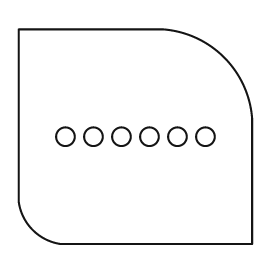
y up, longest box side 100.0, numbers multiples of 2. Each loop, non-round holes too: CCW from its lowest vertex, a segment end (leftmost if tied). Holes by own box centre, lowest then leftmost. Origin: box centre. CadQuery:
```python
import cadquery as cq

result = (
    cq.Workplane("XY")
    .moveTo(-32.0, -46.0)
    .lineTo(50.0, -46.0)
    .lineTo(50.0, 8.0)
    .threePointArc((38.0, 34.0), (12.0, 46.0))
    .lineTo(-50.0, 46.0)
    .lineTo(-50.0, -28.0)
    .threePointArc((-44.0, -40.0), (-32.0, -46.0))
    .close()
    .moveTo(-30.0, 0.0)
    .circle(4.0)
    .moveTo(-18.0, 0.0)
    .circle(4.0)
    .moveTo(-6.0, 0.0)
    .circle(4.0)
    .moveTo(6.0, 0.0)
    .circle(4.0)
    .moveTo(18.0, 0.0)
    .circle(4.0)
    .moveTo(30.0, 0.0)
    .circle(4.0)
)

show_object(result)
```